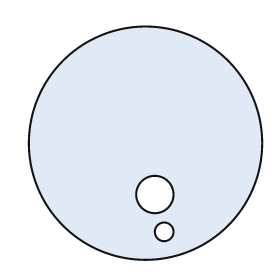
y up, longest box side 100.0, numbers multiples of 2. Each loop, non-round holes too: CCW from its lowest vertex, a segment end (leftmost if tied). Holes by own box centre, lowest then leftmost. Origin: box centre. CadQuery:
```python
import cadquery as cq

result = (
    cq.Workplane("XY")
    .moveTo(0.0, 0.0)
    .circle(50.0)
    .moveTo(8.0, -38.0)
    .circle(4.0)
    .moveTo(4.0, -22.0)
    .circle(8.0)
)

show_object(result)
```